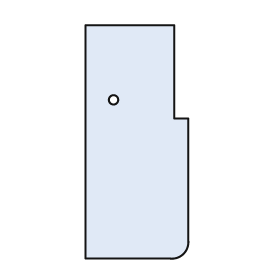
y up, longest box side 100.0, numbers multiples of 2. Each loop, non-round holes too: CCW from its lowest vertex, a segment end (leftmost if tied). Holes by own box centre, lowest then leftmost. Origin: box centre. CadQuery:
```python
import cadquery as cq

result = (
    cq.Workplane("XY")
    .moveTo(-22.0, -50.0)
    .lineTo(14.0, -50.0)
    .threePointArc((20.0, -48.0), (22.0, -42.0))
    .lineTo(22.0, 10.0)
    .lineTo(16.0, 10.0)
    .lineTo(16.0, 50.0)
    .lineTo(-22.0, 50.0)
    .close()
    .moveTo(-10.0, 18.0)
    .circle(2.0)
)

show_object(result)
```